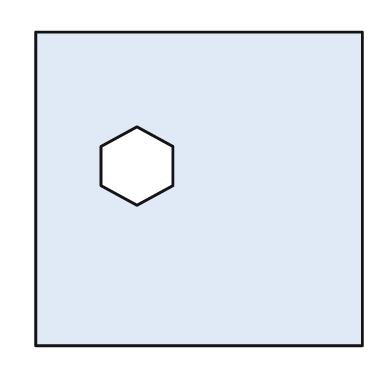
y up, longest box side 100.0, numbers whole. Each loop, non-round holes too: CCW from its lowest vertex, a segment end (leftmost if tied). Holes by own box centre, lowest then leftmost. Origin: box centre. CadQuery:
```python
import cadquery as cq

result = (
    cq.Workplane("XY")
    .moveTo(-50.0, -48.0)
    .lineTo(50.0, -48.0)
    .lineTo(50.0, 48.0)
    .lineTo(-50.0, 48.0)
    .close()
    .moveTo(-19.0, -5.0)
    .lineTo(-8.0, 1.0)
    .lineTo(-8.0, 13.0)
    .lineTo(-19.0, 19.0)
    .lineTo(-30.0, 13.0)
    .lineTo(-30.0, 1.0)
    .close()
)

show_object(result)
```